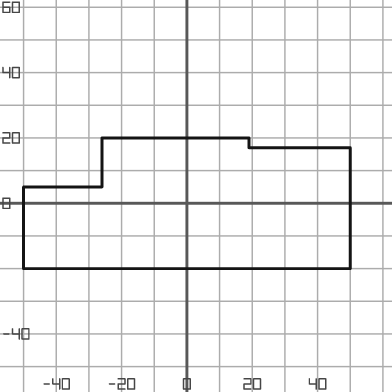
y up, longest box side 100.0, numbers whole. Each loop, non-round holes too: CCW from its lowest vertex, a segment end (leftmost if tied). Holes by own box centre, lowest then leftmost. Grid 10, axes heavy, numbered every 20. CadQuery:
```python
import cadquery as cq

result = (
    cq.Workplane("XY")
    .moveTo(-50.0, -20.0)
    .lineTo(50.0, -20.0)
    .lineTo(50.0, 17.0)
    .lineTo(19.0, 17.0)
    .lineTo(19.0, 20.0)
    .lineTo(-26.0, 20.0)
    .lineTo(-26.0, 5.0)
    .lineTo(-50.0, 5.0)
    .close()
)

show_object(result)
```